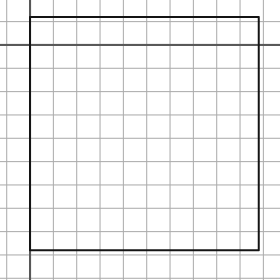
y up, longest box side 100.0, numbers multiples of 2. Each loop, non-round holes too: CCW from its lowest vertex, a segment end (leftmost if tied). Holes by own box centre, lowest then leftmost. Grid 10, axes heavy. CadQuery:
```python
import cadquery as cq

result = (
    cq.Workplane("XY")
    .moveTo(0.0, -88.0)
    .lineTo(98.0, -88.0)
    .lineTo(98.0, 12.0)
    .lineTo(0.0, 12.0)
    .close()
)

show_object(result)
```